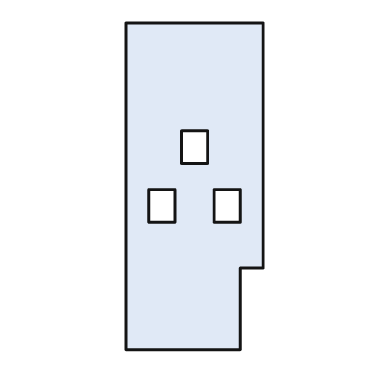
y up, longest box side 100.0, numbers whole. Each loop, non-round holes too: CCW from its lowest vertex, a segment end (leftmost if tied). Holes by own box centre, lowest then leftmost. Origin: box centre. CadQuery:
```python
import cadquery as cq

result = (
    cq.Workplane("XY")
    .moveTo(-21.0, -50.0)
    .lineTo(14.0, -50.0)
    .lineTo(14.0, -25.0)
    .lineTo(21.0, -25.0)
    .lineTo(21.0, 50.0)
    .lineTo(-21.0, 50.0)
    .close()
    .moveTo(-14.0, -11.0)
    .lineTo(-6.0, -11.0)
    .lineTo(-6.0, -1.0)
    .lineTo(-14.0, -1.0)
    .close()
    .moveTo(6.0, -11.0)
    .lineTo(14.0, -11.0)
    .lineTo(14.0, -1.0)
    .lineTo(6.0, -1.0)
    .close()
    .moveTo(-4.0, 7.0)
    .lineTo(4.0, 7.0)
    .lineTo(4.0, 17.0)
    .lineTo(-4.0, 17.0)
    .close()
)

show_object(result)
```